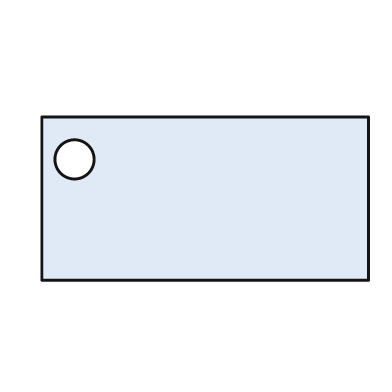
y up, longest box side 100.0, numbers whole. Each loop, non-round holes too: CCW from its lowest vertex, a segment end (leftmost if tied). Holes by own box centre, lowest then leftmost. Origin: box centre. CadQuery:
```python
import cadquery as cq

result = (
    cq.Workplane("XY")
    .moveTo(-50.0, -25.0)
    .lineTo(50.0, -25.0)
    .lineTo(50.0, 25.0)
    .lineTo(-50.0, 25.0)
    .close()
    .moveTo(-40.0, 12.0)
    .circle(6.0)
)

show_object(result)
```